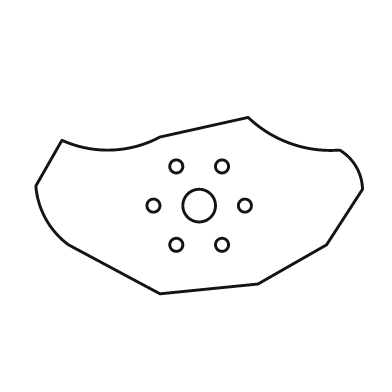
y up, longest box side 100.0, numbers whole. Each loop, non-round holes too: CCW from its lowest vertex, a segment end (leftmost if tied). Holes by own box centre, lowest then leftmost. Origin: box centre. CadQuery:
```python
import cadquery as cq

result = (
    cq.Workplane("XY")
    .moveTo(-12.0, -27.0)
    .lineTo(18.0, -24.0)
    .lineTo(39.0, -12.0)
    .lineTo(50.0, 5.0)
    .threePointArc((48.0, 12.0), (43.0, 17.0))
    .threePointArc((28.0, 19.0), (15.0, 27.0))
    .lineTo(-12.0, 21.0)
    .threePointArc((-27.0, 17.0), (-42.0, 20.0))
    .lineTo(-50.0, 6.0)
    .threePointArc((-47.0, -4.0), (-40.0, -12.0))
    .close()
    .moveTo(-7.0, -12.0)
    .circle(2.0)
    .moveTo(7.0, -12.0)
    .circle(2.0)
    .moveTo(-14.0, 0.0)
    .circle(2.0)
    .moveTo(0.0, 0.0)
    .circle(5.0)
    .moveTo(14.0, 0.0)
    .circle(2.0)
    .moveTo(-7.0, 12.0)
    .circle(2.0)
    .moveTo(7.0, 12.0)
    .circle(2.0)
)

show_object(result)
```